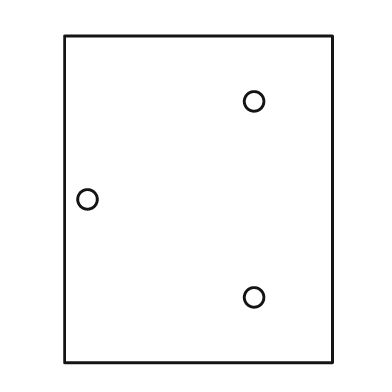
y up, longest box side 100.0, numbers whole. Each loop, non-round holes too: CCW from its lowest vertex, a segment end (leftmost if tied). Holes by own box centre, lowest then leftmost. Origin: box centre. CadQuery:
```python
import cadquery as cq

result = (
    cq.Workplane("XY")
    .moveTo(-41.0, -50.0)
    .lineTo(41.0, -50.0)
    .lineTo(41.0, 50.0)
    .lineTo(-41.0, 50.0)
    .close()
    .moveTo(17.0, -30.0)
    .circle(3.0)
    .moveTo(-34.0, 0.0)
    .circle(3.0)
    .moveTo(17.0, 30.0)
    .circle(3.0)
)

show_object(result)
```